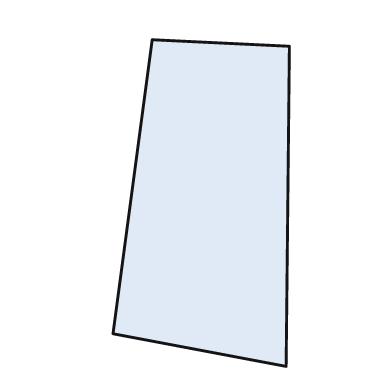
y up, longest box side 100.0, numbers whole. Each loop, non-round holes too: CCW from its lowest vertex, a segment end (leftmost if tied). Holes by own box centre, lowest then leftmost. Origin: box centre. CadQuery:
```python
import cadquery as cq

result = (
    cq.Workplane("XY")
    .moveTo(26.0, -50.0)
    .lineTo(27.0, 48.0)
    .lineTo(-15.0, 50.0)
    .lineTo(-27.0, -40.0)
    .close()
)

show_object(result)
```